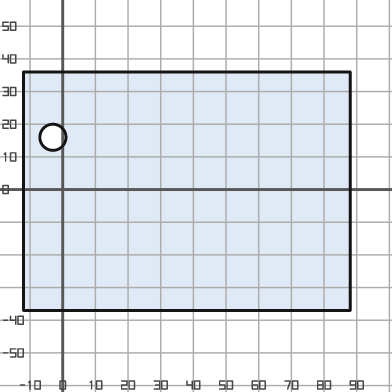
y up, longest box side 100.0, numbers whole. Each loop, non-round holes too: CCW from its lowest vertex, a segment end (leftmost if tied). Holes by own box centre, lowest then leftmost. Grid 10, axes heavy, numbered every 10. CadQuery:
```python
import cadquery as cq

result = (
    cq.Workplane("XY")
    .moveTo(-12.0, -37.0)
    .lineTo(88.0, -37.0)
    .lineTo(88.0, 36.0)
    .lineTo(-12.0, 36.0)
    .close()
    .moveTo(-3.0, 16.0)
    .circle(4.0)
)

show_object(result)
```